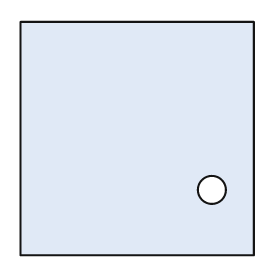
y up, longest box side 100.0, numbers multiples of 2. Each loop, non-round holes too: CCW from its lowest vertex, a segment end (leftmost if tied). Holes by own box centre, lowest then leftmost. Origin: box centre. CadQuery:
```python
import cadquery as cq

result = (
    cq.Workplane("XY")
    .moveTo(-50.0, -50.0)
    .lineTo(50.0, -50.0)
    .lineTo(50.0, 50.0)
    .lineTo(-50.0, 50.0)
    .close()
    .moveTo(32.0, -22.0)
    .circle(6.0)
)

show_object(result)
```